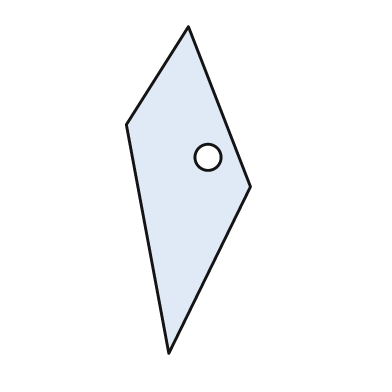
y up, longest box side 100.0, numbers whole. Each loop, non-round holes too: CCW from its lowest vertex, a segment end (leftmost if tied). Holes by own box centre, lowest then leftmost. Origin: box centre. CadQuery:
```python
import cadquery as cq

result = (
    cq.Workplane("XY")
    .moveTo(-6.0, -50.0)
    .lineTo(19.0, 1.0)
    .lineTo(0.0, 50.0)
    .lineTo(-19.0, 20.0)
    .close()
    .moveTo(6.0, 10.0)
    .circle(4.0)
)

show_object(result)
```